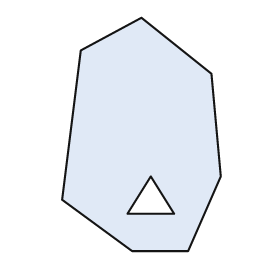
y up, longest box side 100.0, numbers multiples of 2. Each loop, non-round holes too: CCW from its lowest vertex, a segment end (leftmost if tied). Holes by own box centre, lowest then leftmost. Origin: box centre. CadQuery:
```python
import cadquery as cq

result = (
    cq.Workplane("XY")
    .moveTo(-4.0, -50.0)
    .lineTo(20.0, -50.0)
    .lineTo(34.0, -18.0)
    .lineTo(30.0, 26.0)
    .lineTo(0.0, 50.0)
    .lineTo(-26.0, 36.0)
    .lineTo(-34.0, -28.0)
    .close()
    .moveTo(-6.0, -34.0)
    .lineTo(14.0, -34.0)
    .lineTo(4.0, -18.0)
    .close()
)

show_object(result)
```